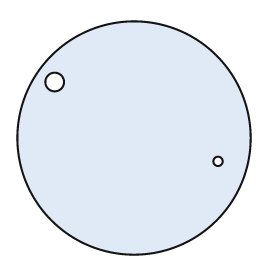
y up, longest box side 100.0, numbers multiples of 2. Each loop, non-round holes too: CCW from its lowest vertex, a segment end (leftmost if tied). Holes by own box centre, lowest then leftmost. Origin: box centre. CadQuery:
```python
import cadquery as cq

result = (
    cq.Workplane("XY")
    .moveTo(0.0, 0.0)
    .circle(50.0)
    .moveTo(36.0, -10.0)
    .circle(2.0)
    .moveTo(-34.0, 24.0)
    .circle(4.0)
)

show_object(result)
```